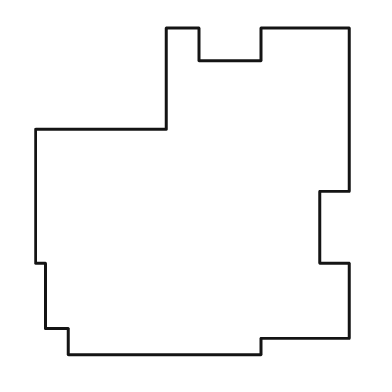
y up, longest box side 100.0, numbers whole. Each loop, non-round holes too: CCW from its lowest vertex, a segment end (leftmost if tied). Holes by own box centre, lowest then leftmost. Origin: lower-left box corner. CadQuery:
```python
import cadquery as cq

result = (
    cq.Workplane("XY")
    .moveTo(10.0, 0.0)
    .lineTo(69.0, 0.0)
    .lineTo(69.0, 5.0)
    .lineTo(96.0, 5.0)
    .lineTo(96.0, 28.0)
    .lineTo(87.0, 28.0)
    .lineTo(87.0, 50.0)
    .lineTo(96.0, 50.0)
    .lineTo(96.0, 100.0)
    .lineTo(69.0, 100.0)
    .lineTo(69.0, 90.0)
    .lineTo(50.0, 90.0)
    .lineTo(50.0, 100.0)
    .lineTo(40.0, 100.0)
    .lineTo(40.0, 69.0)
    .lineTo(0.0, 69.0)
    .lineTo(0.0, 28.0)
    .lineTo(3.0, 28.0)
    .lineTo(3.0, 8.0)
    .lineTo(10.0, 8.0)
    .close()
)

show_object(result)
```